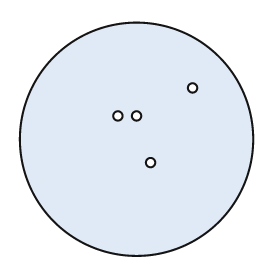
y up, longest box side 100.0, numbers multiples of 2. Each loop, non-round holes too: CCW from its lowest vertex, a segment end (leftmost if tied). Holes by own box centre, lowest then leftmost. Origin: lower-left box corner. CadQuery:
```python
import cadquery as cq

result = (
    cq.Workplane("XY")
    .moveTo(50.0, 50.0)
    .circle(50.0)
    .moveTo(56.0, 40.0)
    .circle(2.0)
    .moveTo(42.0, 60.0)
    .circle(2.0)
    .moveTo(50.0, 60.0)
    .circle(2.0)
    .moveTo(74.0, 72.0)
    .circle(2.0)
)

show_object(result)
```